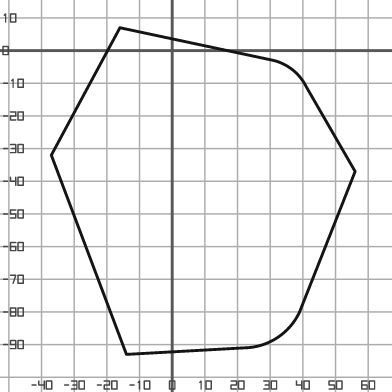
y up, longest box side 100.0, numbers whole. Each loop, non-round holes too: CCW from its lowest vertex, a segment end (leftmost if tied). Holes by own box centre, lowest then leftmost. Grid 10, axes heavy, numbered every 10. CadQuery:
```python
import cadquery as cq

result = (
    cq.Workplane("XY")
    .moveTo(-14.0, -93.0)
    .lineTo(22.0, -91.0)
    .threePointArc((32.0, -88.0), (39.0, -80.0))
    .lineTo(56.0, -37.0)
    .lineTo(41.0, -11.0)
    .threePointArc((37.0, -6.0), (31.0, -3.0))
    .lineTo(-16.0, 7.0)
    .lineTo(-37.0, -32.0)
    .close()
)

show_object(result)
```